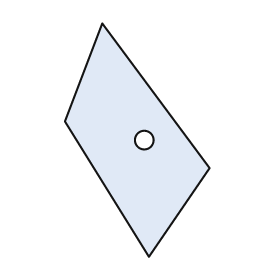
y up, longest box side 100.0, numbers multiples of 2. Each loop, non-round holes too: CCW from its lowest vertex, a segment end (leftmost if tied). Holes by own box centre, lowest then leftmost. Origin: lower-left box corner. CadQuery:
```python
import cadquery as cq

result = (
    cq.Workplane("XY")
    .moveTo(36.0, 0.0)
    .lineTo(62.0, 38.0)
    .lineTo(16.0, 100.0)
    .lineTo(0.0, 58.0)
    .close()
    .moveTo(34.0, 50.0)
    .circle(4.0)
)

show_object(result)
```